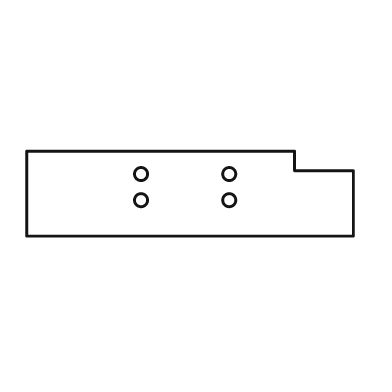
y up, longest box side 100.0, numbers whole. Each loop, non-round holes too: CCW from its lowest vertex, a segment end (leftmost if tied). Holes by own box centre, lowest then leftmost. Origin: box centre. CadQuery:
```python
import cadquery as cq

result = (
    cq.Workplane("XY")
    .moveTo(-50.0, -13.0)
    .lineTo(50.0, -13.0)
    .lineTo(50.0, 7.0)
    .lineTo(32.0, 7.0)
    .lineTo(32.0, 13.0)
    .lineTo(-50.0, 13.0)
    .close()
    .moveTo(-15.0, -2.0)
    .circle(2.0)
    .moveTo(12.0, -2.0)
    .circle(2.0)
    .moveTo(-15.0, 6.0)
    .circle(2.0)
    .moveTo(12.0, 6.0)
    .circle(2.0)
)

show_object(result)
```